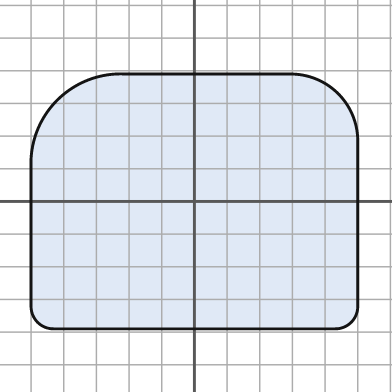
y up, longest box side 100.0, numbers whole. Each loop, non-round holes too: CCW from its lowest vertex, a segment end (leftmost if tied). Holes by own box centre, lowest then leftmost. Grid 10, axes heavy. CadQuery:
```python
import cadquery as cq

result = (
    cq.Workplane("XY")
    .moveTo(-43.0, -39.0)
    .lineTo(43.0, -39.0)
    .threePointArc((48.0, -37.0), (50.0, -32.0))
    .lineTo(50.0, 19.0)
    .threePointArc((44.0, 33.0), (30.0, 39.0))
    .lineTo(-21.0, 39.0)
    .threePointArc((-42.0, 31.0), (-50.0, 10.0))
    .lineTo(-50.0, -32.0)
    .threePointArc((-48.0, -37.0), (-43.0, -39.0))
    .close()
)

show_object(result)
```